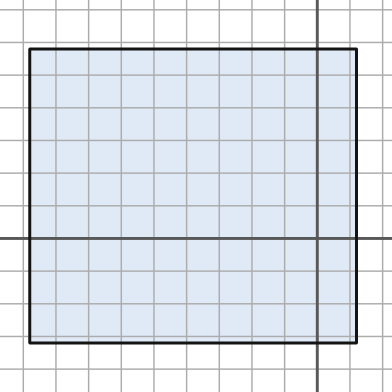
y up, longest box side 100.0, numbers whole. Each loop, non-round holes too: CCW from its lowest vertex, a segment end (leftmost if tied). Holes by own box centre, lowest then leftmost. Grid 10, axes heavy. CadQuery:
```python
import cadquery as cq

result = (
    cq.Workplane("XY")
    .moveTo(-88.0, -32.0)
    .lineTo(12.0, -32.0)
    .lineTo(12.0, 58.0)
    .lineTo(-88.0, 58.0)
    .close()
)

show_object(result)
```